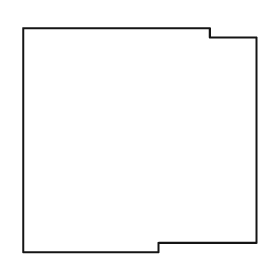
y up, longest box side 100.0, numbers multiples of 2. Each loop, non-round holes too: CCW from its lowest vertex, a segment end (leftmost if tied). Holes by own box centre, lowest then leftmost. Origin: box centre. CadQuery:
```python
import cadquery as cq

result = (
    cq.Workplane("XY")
    .moveTo(-50.0, -48.0)
    .lineTo(8.0, -48.0)
    .lineTo(8.0, -44.0)
    .lineTo(50.0, -44.0)
    .lineTo(50.0, 44.0)
    .lineTo(30.0, 44.0)
    .lineTo(30.0, 48.0)
    .lineTo(-50.0, 48.0)
    .close()
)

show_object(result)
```